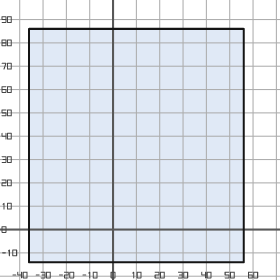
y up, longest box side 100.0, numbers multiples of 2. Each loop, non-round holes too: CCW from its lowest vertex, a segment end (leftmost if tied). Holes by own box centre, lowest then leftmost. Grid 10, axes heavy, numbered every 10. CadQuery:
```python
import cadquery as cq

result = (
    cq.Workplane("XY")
    .moveTo(-36.0, -14.0)
    .lineTo(56.0, -14.0)
    .lineTo(56.0, 86.0)
    .lineTo(-36.0, 86.0)
    .close()
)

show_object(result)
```